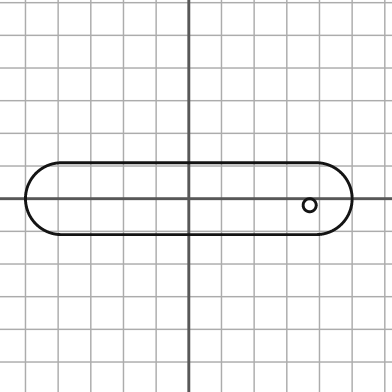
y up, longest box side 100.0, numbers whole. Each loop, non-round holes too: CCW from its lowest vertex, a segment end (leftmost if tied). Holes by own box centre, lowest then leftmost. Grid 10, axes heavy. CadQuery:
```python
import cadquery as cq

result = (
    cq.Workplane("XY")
    .moveTo(-39.0, -11.0)
    .lineTo(39.0, -11.0)
    .threePointArc((50.0, 0.0), (39.0, 11.0))
    .lineTo(-39.0, 11.0)
    .threePointArc((-50.0, 0.0), (-39.0, -11.0))
    .close()
    .moveTo(37.0, -2.0)
    .circle(2.0)
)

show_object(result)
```